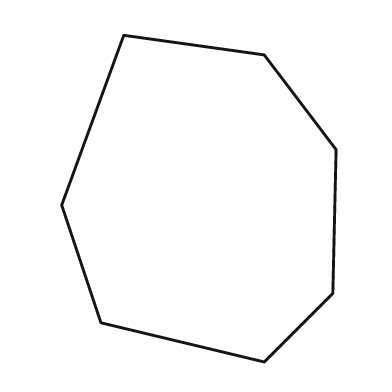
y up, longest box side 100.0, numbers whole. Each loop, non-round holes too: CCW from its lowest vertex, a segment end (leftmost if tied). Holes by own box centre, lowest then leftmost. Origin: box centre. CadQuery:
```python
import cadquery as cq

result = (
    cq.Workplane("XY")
    .moveTo(20.0, -50.0)
    .lineTo(41.0, -29.0)
    .lineTo(42.0, 15.0)
    .lineTo(20.0, 44.0)
    .lineTo(-23.0, 50.0)
    .lineTo(-42.0, -2.0)
    .lineTo(-30.0, -38.0)
    .close()
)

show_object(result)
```